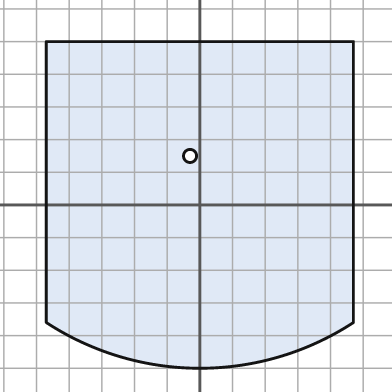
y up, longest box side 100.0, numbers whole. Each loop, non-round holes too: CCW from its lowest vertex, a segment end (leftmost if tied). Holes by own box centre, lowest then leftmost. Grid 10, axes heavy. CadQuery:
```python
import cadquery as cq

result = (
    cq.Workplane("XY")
    .moveTo(-47.0, -36.0)
    .threePointArc((0.0, -50.0), (47.0, -36.0))
    .lineTo(47.0, 50.0)
    .lineTo(-47.0, 50.0)
    .close()
    .moveTo(-3.0, 15.0)
    .circle(2.0)
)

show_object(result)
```